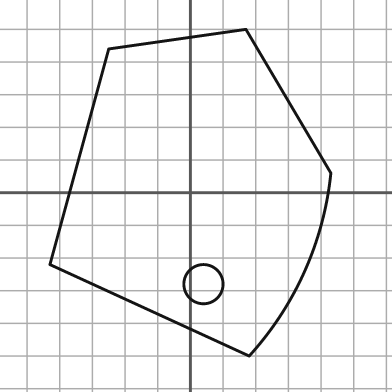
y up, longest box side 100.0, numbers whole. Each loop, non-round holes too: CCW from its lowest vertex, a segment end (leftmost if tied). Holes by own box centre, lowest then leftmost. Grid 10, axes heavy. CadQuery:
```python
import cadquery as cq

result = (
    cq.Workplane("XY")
    .moveTo(18.0, -50.0)
    .threePointArc((35.0, -24.0), (43.0, 6.0))
    .lineTo(17.0, 50.0)
    .lineTo(-25.0, 44.0)
    .lineTo(-43.0, -22.0)
    .close()
    .moveTo(4.0, -28.0)
    .circle(6.0)
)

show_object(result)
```